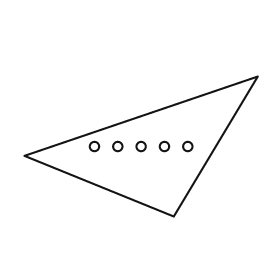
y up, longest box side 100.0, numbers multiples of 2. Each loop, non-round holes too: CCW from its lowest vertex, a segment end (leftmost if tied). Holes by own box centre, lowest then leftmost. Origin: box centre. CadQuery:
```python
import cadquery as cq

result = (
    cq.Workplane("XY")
    .moveTo(14.0, -30.0)
    .lineTo(50.0, 30.0)
    .lineTo(-50.0, -4.0)
    .close()
    .moveTo(-20.0, 0.0)
    .circle(2.0)
    .moveTo(-10.0, 0.0)
    .circle(2.0)
    .moveTo(0.0, 0.0)
    .circle(2.0)
    .moveTo(10.0, 0.0)
    .circle(2.0)
    .moveTo(20.0, 0.0)
    .circle(2.0)
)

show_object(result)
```